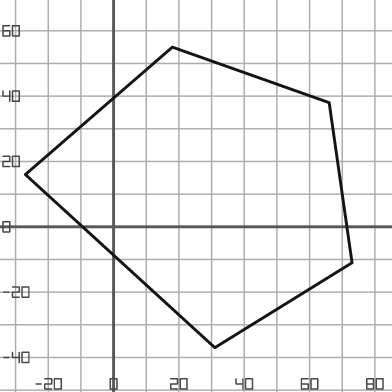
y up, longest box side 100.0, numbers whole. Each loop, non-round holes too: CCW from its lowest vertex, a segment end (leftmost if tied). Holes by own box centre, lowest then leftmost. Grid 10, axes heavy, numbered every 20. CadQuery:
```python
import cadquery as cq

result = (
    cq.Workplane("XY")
    .moveTo(31.0, -37.0)
    .lineTo(73.0, -11.0)
    .lineTo(66.0, 38.0)
    .lineTo(18.0, 55.0)
    .lineTo(-27.0, 16.0)
    .close()
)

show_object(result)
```